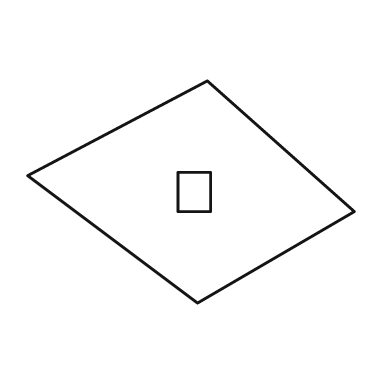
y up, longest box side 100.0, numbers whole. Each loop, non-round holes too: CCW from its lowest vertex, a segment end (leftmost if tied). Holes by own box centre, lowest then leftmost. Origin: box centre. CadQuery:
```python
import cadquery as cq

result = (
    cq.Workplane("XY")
    .moveTo(2.0, -34.0)
    .lineTo(50.0, -6.0)
    .lineTo(5.0, 34.0)
    .lineTo(-50.0, 5.0)
    .close()
    .moveTo(-4.0, -6.0)
    .lineTo(6.0, -6.0)
    .lineTo(6.0, 6.0)
    .lineTo(-4.0, 6.0)
    .close()
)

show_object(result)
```